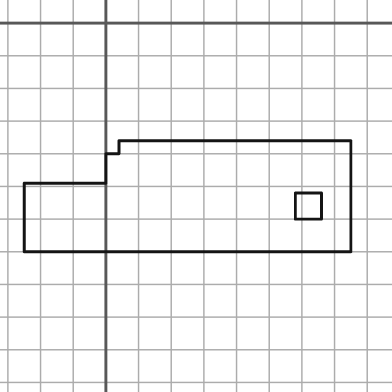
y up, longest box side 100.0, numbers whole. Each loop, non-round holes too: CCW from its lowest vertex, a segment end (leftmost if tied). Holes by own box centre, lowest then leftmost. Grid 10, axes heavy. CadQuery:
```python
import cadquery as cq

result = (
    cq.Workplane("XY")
    .moveTo(-25.0, -70.0)
    .lineTo(75.0, -70.0)
    .lineTo(75.0, -36.0)
    .lineTo(4.0, -36.0)
    .lineTo(4.0, -40.0)
    .lineTo(0.0, -40.0)
    .lineTo(0.0, -49.0)
    .lineTo(-25.0, -49.0)
    .close()
    .moveTo(58.0, -60.0)
    .lineTo(66.0, -60.0)
    .lineTo(66.0, -52.0)
    .lineTo(58.0, -52.0)
    .close()
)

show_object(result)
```